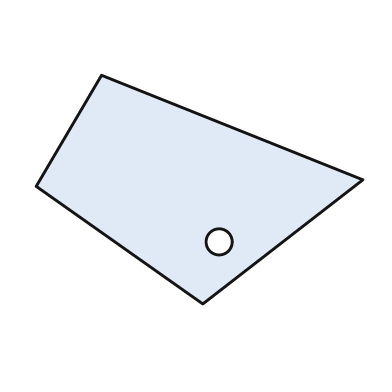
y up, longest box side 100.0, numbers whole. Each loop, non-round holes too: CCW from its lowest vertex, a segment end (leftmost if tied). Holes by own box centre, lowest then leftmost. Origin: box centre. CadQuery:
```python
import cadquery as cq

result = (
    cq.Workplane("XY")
    .moveTo(1.0, -35.0)
    .lineTo(50.0, 3.0)
    .lineTo(-30.0, 35.0)
    .lineTo(-50.0, 1.0)
    .close()
    .moveTo(6.0, -16.0)
    .circle(4.0)
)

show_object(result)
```